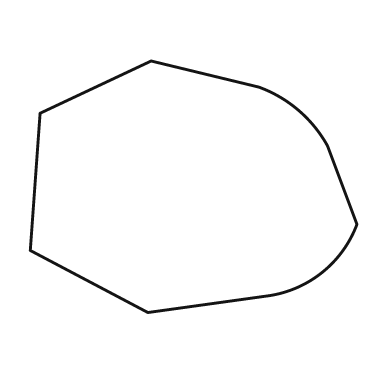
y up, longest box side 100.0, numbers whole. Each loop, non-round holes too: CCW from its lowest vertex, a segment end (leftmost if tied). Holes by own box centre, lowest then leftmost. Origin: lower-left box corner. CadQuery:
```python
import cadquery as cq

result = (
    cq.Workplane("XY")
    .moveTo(36.0, 0.0)
    .lineTo(72.0, 5.0)
    .threePointArc((89.0, 12.0), (100.0, 27.0))
    .lineTo(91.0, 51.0)
    .threePointArc((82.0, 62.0), (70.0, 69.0))
    .lineTo(37.0, 77.0)
    .lineTo(3.0, 61.0)
    .lineTo(0.0, 19.0)
    .close()
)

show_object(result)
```